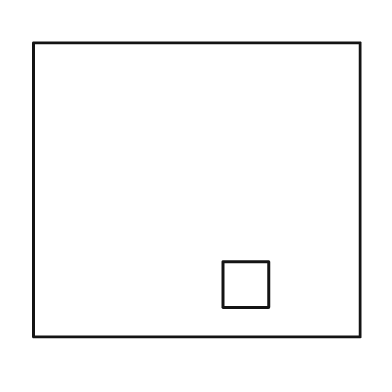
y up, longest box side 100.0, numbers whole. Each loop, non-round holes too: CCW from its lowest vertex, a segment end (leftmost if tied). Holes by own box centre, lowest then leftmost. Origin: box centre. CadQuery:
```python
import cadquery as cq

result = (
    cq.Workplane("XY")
    .moveTo(-50.0, -45.0)
    .lineTo(50.0, -45.0)
    .lineTo(50.0, 45.0)
    .lineTo(-50.0, 45.0)
    .close()
    .moveTo(8.0, -36.0)
    .lineTo(22.0, -36.0)
    .lineTo(22.0, -22.0)
    .lineTo(8.0, -22.0)
    .close()
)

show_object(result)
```